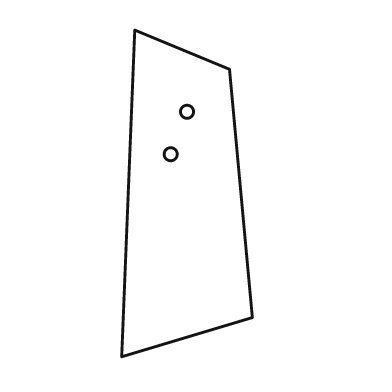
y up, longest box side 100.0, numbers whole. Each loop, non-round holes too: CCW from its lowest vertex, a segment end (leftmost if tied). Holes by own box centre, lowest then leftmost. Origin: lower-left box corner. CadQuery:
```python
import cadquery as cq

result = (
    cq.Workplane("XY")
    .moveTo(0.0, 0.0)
    .lineTo(40.0, 12.0)
    .lineTo(33.0, 88.0)
    .lineTo(4.0, 100.0)
    .close()
    .moveTo(15.0, 62.0)
    .circle(2.0)
    .moveTo(20.0, 75.0)
    .circle(2.0)
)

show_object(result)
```